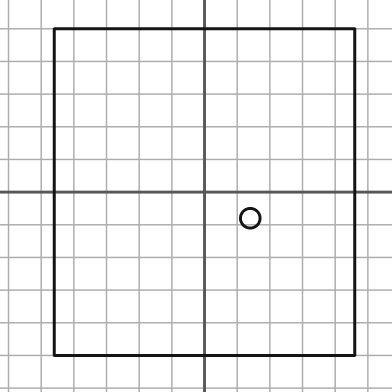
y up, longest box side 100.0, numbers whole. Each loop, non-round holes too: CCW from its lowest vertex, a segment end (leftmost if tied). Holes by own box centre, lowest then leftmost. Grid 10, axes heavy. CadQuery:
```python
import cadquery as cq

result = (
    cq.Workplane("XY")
    .moveTo(-46.0, -50.0)
    .lineTo(46.0, -50.0)
    .lineTo(46.0, 50.0)
    .lineTo(-46.0, 50.0)
    .close()
    .moveTo(14.0, -8.0)
    .circle(3.0)
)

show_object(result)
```